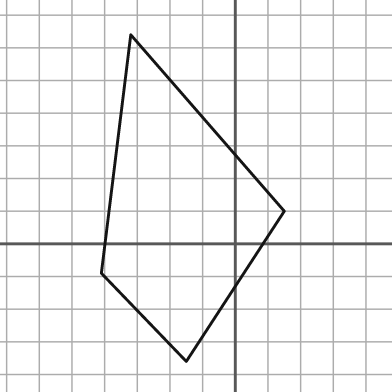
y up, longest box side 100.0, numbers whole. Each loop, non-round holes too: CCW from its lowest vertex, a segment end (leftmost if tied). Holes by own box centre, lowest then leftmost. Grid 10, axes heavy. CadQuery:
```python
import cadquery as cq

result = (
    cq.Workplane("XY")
    .moveTo(-15.0, -36.0)
    .lineTo(15.0, 10.0)
    .lineTo(-32.0, 64.0)
    .lineTo(-41.0, -9.0)
    .close()
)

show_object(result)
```